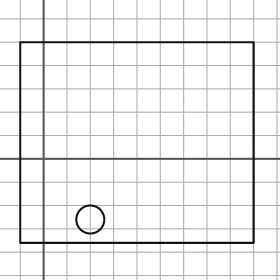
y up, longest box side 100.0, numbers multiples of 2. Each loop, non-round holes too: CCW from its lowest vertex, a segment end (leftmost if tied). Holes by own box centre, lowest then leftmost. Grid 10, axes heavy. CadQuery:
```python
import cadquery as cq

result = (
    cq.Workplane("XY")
    .moveTo(-10.0, -36.0)
    .lineTo(90.0, -36.0)
    .lineTo(90.0, 50.0)
    .lineTo(-10.0, 50.0)
    .close()
    .moveTo(20.0, -26.0)
    .circle(6.0)
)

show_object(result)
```